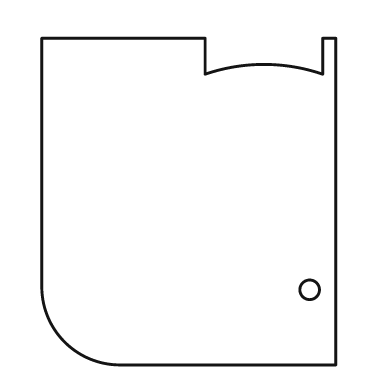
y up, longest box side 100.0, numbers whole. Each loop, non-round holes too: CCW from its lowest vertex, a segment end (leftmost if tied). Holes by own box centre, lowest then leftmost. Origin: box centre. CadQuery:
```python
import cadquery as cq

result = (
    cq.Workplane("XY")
    .moveTo(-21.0, -50.0)
    .lineTo(45.0, -50.0)
    .lineTo(45.0, 50.0)
    .lineTo(41.0, 50.0)
    .lineTo(41.0, 39.0)
    .threePointArc((23.0, 42.0), (5.0, 39.0))
    .lineTo(5.0, 50.0)
    .lineTo(-45.0, 50.0)
    .lineTo(-45.0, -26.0)
    .threePointArc((-38.0, -43.0), (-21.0, -50.0))
    .close()
    .moveTo(37.0, -27.0)
    .circle(3.0)
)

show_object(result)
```